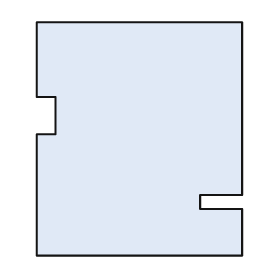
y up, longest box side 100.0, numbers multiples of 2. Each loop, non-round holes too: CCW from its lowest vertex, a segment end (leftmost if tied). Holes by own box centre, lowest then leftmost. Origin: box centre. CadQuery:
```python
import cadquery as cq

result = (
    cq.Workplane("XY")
    .moveTo(-44.0, -50.0)
    .lineTo(44.0, -50.0)
    .lineTo(44.0, -30.0)
    .lineTo(26.0, -30.0)
    .lineTo(26.0, -24.0)
    .lineTo(44.0, -24.0)
    .lineTo(44.0, 50.0)
    .lineTo(-44.0, 50.0)
    .lineTo(-44.0, 18.0)
    .lineTo(-36.0, 18.0)
    .lineTo(-36.0, 2.0)
    .lineTo(-44.0, 2.0)
    .close()
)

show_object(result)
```